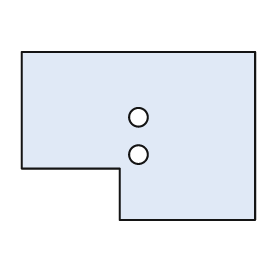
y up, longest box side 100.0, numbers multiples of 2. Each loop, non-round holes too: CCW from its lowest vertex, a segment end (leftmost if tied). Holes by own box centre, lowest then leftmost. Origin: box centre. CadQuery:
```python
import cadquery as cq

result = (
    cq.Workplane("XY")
    .moveTo(-8.0, -36.0)
    .lineTo(50.0, -36.0)
    .lineTo(50.0, 36.0)
    .lineTo(-50.0, 36.0)
    .lineTo(-50.0, -14.0)
    .lineTo(-8.0, -14.0)
    .close()
    .moveTo(0.0, -8.0)
    .circle(4.0)
    .moveTo(0.0, 8.0)
    .circle(4.0)
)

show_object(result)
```